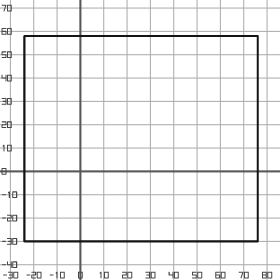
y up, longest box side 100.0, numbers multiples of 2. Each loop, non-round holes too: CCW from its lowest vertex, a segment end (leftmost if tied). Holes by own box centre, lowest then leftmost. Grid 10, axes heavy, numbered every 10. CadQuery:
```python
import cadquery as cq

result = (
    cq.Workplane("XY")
    .moveTo(-24.0, -30.0)
    .lineTo(76.0, -30.0)
    .lineTo(76.0, 58.0)
    .lineTo(-24.0, 58.0)
    .close()
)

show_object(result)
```